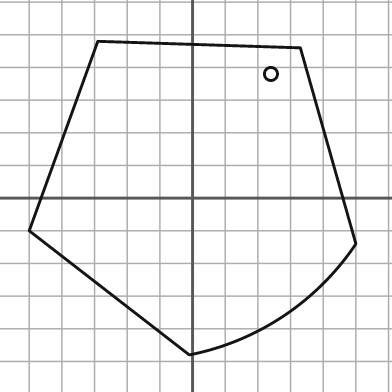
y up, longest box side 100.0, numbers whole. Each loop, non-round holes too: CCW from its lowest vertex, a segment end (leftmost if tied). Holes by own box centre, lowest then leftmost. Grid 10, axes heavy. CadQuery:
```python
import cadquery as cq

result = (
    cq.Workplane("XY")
    .moveTo(-1.0, -48.0)
    .threePointArc((28.0, -36.0), (50.0, -14.0))
    .lineTo(33.0, 46.0)
    .lineTo(-29.0, 48.0)
    .lineTo(-50.0, -10.0)
    .close()
    .moveTo(24.0, 38.0)
    .circle(2.0)
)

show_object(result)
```